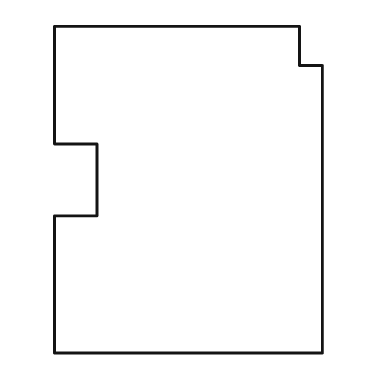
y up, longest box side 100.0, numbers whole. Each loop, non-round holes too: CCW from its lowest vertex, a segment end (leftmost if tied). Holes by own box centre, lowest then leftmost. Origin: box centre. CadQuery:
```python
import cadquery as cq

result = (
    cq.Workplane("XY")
    .moveTo(-41.0, -50.0)
    .lineTo(41.0, -50.0)
    .lineTo(41.0, 38.0)
    .lineTo(34.0, 38.0)
    .lineTo(34.0, 50.0)
    .lineTo(-41.0, 50.0)
    .lineTo(-41.0, 14.0)
    .lineTo(-28.0, 14.0)
    .lineTo(-28.0, -8.0)
    .lineTo(-41.0, -8.0)
    .close()
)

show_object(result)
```